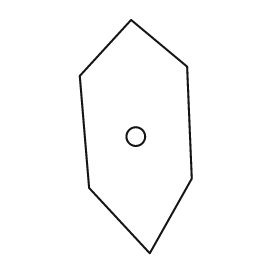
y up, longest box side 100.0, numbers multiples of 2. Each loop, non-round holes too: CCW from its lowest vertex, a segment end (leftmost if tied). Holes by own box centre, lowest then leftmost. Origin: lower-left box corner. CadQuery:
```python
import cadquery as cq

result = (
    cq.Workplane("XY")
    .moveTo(30.0, 0.0)
    .lineTo(48.0, 32.0)
    .lineTo(46.0, 80.0)
    .lineTo(22.0, 100.0)
    .lineTo(0.0, 76.0)
    .lineTo(4.0, 28.0)
    .close()
    .moveTo(24.0, 50.0)
    .circle(4.0)
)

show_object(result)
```